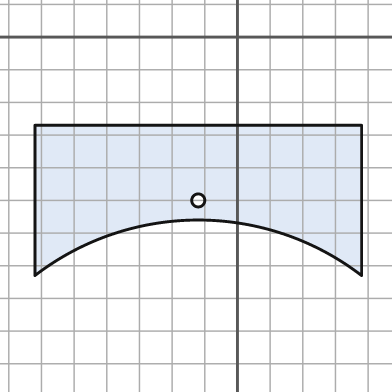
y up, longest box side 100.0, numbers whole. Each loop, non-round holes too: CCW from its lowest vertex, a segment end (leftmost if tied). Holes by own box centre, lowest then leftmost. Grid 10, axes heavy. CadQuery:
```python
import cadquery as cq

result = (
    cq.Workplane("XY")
    .moveTo(-62.0, -73.0)
    .threePointArc((-12.0, -56.0), (38.0, -73.0))
    .lineTo(38.0, -27.0)
    .lineTo(-62.0, -27.0)
    .close()
    .moveTo(-12.0, -50.0)
    .circle(2.0)
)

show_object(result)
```